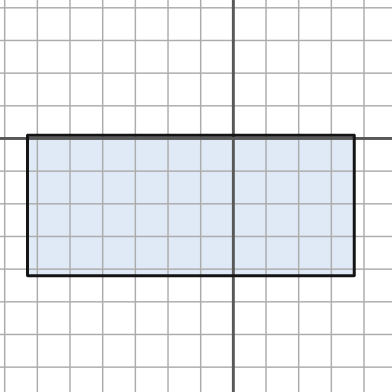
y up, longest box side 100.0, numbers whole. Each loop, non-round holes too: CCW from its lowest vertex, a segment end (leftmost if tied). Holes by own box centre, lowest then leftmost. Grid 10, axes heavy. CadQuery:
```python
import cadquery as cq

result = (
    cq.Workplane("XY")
    .moveTo(-63.0, -42.0)
    .lineTo(37.0, -42.0)
    .lineTo(37.0, 1.0)
    .lineTo(-63.0, 1.0)
    .close()
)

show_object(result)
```